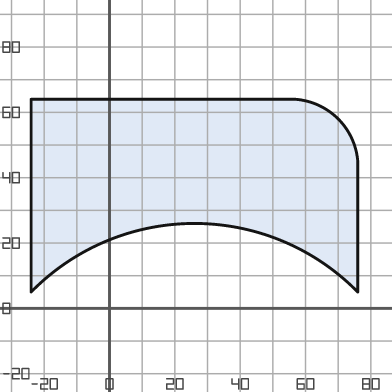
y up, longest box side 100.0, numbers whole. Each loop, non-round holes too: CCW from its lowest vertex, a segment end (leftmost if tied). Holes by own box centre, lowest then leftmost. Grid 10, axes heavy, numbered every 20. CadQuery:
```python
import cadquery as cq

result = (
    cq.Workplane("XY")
    .moveTo(-24.0, 5.0)
    .threePointArc((26.0, 26.0), (76.0, 5.0))
    .lineTo(76.0, 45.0)
    .threePointArc((70.0, 58.0), (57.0, 64.0))
    .lineTo(-24.0, 64.0)
    .close()
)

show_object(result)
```